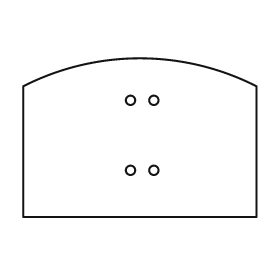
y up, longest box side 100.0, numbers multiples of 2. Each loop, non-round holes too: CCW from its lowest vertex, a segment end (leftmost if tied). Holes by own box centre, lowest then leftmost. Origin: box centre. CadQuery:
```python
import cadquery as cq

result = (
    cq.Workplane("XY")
    .moveTo(-50.0, -34.0)
    .lineTo(50.0, -34.0)
    .lineTo(50.0, 22.0)
    .threePointArc((0.0, 34.0), (-50.0, 22.0))
    .close()
    .moveTo(-4.0, -14.0)
    .circle(2.0)
    .moveTo(6.0, -14.0)
    .circle(2.0)
    .moveTo(-4.0, 16.0)
    .circle(2.0)
    .moveTo(6.0, 16.0)
    .circle(2.0)
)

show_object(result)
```